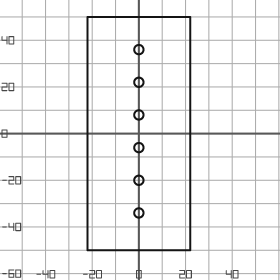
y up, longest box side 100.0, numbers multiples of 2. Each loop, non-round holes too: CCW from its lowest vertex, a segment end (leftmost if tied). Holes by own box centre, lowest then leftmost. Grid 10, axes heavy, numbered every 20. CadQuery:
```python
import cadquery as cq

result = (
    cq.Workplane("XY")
    .moveTo(-22.0, -50.0)
    .lineTo(22.0, -50.0)
    .lineTo(22.0, 50.0)
    .lineTo(-22.0, 50.0)
    .close()
    .moveTo(0.0, -34.0)
    .circle(2.0)
    .moveTo(0.0, -20.0)
    .circle(2.0)
    .moveTo(0.0, -6.0)
    .circle(2.0)
    .moveTo(0.0, 8.0)
    .circle(2.0)
    .moveTo(0.0, 22.0)
    .circle(2.0)
    .moveTo(0.0, 36.0)
    .circle(2.0)
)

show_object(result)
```